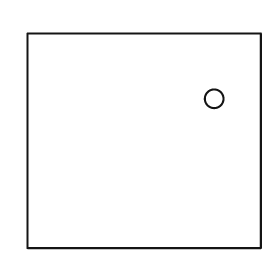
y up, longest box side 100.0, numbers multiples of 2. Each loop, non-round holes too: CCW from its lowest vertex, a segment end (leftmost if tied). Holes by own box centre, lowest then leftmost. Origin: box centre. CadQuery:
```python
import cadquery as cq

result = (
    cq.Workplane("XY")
    .moveTo(-50.0, -46.0)
    .lineTo(50.0, -46.0)
    .lineTo(50.0, 46.0)
    .lineTo(-50.0, 46.0)
    .close()
    .moveTo(30.0, 18.0)
    .circle(4.0)
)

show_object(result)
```